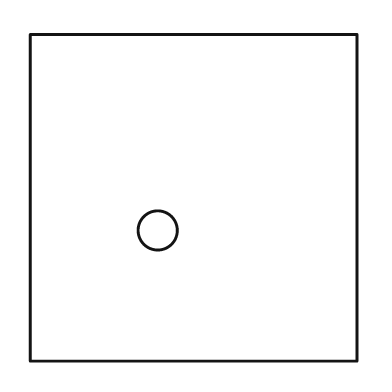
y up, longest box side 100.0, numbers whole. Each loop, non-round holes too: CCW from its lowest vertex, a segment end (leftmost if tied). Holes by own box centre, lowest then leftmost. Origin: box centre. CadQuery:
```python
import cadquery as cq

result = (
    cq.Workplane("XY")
    .moveTo(-50.0, -50.0)
    .lineTo(50.0, -50.0)
    .lineTo(50.0, 50.0)
    .lineTo(-50.0, 50.0)
    .close()
    .moveTo(-11.0, -10.0)
    .circle(6.0)
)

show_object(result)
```